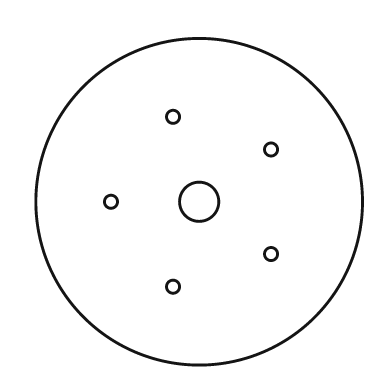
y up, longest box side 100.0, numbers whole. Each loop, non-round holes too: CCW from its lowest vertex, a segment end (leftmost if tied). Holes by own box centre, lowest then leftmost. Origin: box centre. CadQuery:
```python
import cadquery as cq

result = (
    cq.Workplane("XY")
    .moveTo(0.0, 0.0)
    .circle(50.0)
    .moveTo(-8.0, -26.0)
    .circle(2.0)
    .moveTo(22.0, -16.0)
    .circle(2.0)
    .moveTo(-27.0, 0.0)
    .circle(2.0)
    .moveTo(0.0, 0.0)
    .circle(6.0)
    .moveTo(22.0, 16.0)
    .circle(2.0)
    .moveTo(-8.0, 26.0)
    .circle(2.0)
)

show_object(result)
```